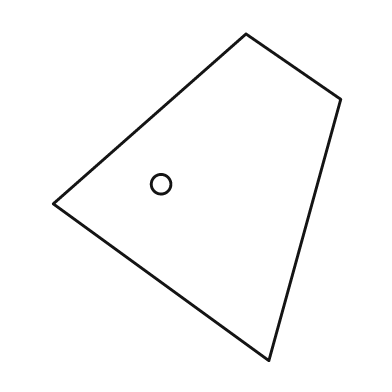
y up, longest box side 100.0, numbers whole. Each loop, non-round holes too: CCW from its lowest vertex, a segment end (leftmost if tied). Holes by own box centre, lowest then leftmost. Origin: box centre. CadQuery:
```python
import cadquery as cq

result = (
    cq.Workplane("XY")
    .moveTo(22.0, -50.0)
    .lineTo(44.0, 30.0)
    .lineTo(15.0, 50.0)
    .lineTo(-44.0, -2.0)
    .close()
    .moveTo(-11.0, 4.0)
    .circle(3.0)
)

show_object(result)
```